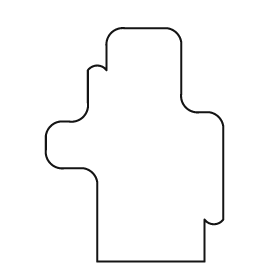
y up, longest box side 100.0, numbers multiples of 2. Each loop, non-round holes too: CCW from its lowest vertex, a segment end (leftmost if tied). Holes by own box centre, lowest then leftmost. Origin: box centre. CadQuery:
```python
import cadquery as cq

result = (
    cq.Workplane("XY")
    .moveTo(-16.0, -50.0)
    .lineTo(30.0, -50.0)
    .lineTo(30.0, -32.0)
    .threePointArc((34.0, -34.0), (38.0, -32.0))
    .lineTo(38.0, 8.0)
    .threePointArc((36.0, 12.0), (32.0, 14.0))
    .lineTo(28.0, 14.0)
    .threePointArc((22.0, 16.0), (20.0, 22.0))
    .lineTo(20.0, 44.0)
    .threePointArc((18.0, 48.0), (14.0, 50.0))
    .lineTo(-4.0, 50.0)
    .threePointArc((-10.0, 48.0), (-12.0, 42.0))
    .lineTo(-12.0, 32.0)
    .threePointArc((-16.0, 34.0), (-20.0, 32.0))
    .lineTo(-20.0, 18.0)
    .threePointArc((-22.0, 12.0), (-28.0, 10.0))
    .lineTo(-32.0, 10.0)
    .threePointArc((-36.0, 8.0), (-38.0, 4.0))
    .lineTo(-38.0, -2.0)
    .threePointArc((-36.0, -8.0), (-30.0, -10.0))
    .lineTo(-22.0, -10.0)
    .threePointArc((-18.0, -12.0), (-16.0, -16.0))
    .close()
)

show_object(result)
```